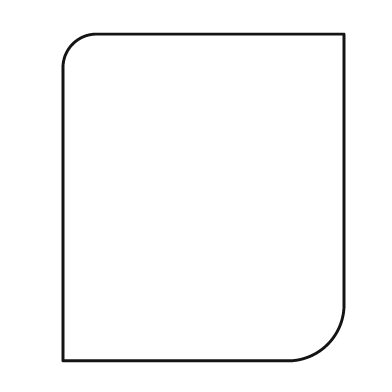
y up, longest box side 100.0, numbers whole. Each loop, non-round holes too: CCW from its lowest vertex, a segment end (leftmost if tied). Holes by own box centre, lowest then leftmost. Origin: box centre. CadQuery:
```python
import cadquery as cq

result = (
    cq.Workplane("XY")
    .moveTo(-43.0, -50.0)
    .lineTo(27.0, -50.0)
    .threePointArc((38.0, -45.0), (43.0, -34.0))
    .lineTo(43.0, 50.0)
    .lineTo(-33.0, 50.0)
    .threePointArc((-40.0, 47.0), (-43.0, 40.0))
    .close()
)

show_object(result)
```